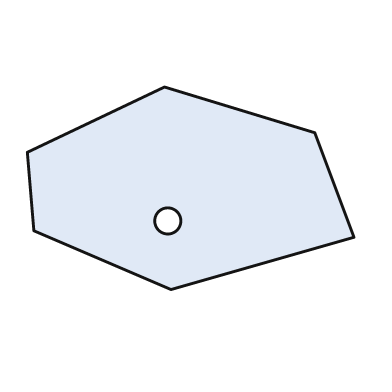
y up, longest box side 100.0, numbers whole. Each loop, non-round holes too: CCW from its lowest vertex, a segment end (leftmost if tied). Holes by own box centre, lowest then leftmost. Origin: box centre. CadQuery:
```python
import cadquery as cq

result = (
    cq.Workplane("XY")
    .moveTo(-6.0, -31.0)
    .lineTo(50.0, -15.0)
    .lineTo(38.0, 17.0)
    .lineTo(-8.0, 31.0)
    .lineTo(-50.0, 11.0)
    .lineTo(-48.0, -13.0)
    .close()
    .moveTo(-7.0, -10.0)
    .circle(4.0)
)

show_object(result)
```